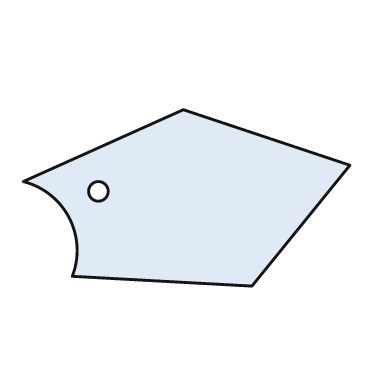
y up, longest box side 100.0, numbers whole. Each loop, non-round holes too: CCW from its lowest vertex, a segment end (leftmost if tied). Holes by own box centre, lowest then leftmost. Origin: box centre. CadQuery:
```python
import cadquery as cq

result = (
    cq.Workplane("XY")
    .moveTo(20.0, -27.0)
    .lineTo(50.0, 10.0)
    .lineTo(-1.0, 27.0)
    .lineTo(-50.0, 5.0)
    .threePointArc((-36.0, -6.0), (-35.0, -24.0))
    .close()
    .moveTo(-27.0, 2.0)
    .circle(3.0)
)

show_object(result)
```